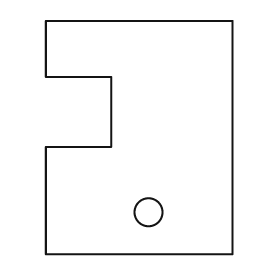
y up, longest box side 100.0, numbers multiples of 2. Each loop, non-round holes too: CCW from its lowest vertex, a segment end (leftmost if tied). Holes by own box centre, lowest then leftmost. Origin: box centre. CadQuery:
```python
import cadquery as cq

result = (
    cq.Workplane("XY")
    .moveTo(-40.0, -50.0)
    .lineTo(40.0, -50.0)
    .lineTo(40.0, 50.0)
    .lineTo(-40.0, 50.0)
    .lineTo(-40.0, 26.0)
    .lineTo(-12.0, 26.0)
    .lineTo(-12.0, -4.0)
    .lineTo(-40.0, -4.0)
    .close()
    .moveTo(4.0, -32.0)
    .circle(6.0)
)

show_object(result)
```